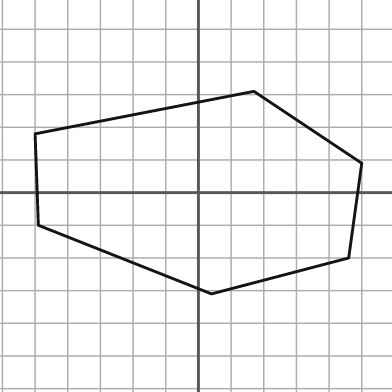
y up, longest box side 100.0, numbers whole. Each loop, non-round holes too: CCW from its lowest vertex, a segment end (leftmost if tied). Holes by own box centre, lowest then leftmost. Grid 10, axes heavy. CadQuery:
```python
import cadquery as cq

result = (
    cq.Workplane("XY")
    .moveTo(4.0, -31.0)
    .lineTo(46.0, -20.0)
    .lineTo(50.0, 9.0)
    .lineTo(17.0, 31.0)
    .lineTo(-50.0, 18.0)
    .lineTo(-49.0, -10.0)
    .close()
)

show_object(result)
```